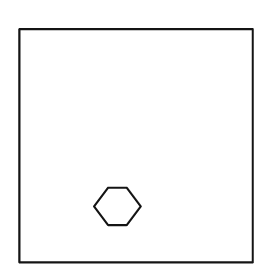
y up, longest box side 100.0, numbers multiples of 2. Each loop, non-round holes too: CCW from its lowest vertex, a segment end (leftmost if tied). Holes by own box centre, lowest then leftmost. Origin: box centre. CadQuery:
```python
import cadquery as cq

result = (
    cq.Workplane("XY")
    .moveTo(-50.0, -50.0)
    .lineTo(50.0, -50.0)
    .lineTo(50.0, 50.0)
    .lineTo(-50.0, 50.0)
    .close()
    .moveTo(-12.0, -34.0)
    .lineTo(-4.0, -34.0)
    .lineTo(2.0, -26.0)
    .lineTo(-4.0, -18.0)
    .lineTo(-12.0, -18.0)
    .lineTo(-18.0, -26.0)
    .close()
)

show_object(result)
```